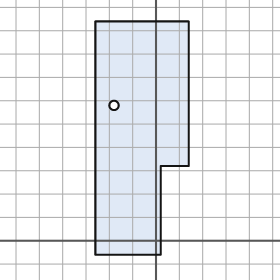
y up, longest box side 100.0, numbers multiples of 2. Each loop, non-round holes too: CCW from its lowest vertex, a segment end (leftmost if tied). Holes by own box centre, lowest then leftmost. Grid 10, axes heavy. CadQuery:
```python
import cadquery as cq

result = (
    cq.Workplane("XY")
    .moveTo(-26.0, -6.0)
    .lineTo(2.0, -6.0)
    .lineTo(2.0, 32.0)
    .lineTo(14.0, 32.0)
    .lineTo(14.0, 94.0)
    .lineTo(-26.0, 94.0)
    .close()
    .moveTo(-18.0, 58.0)
    .circle(2.0)
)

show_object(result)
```